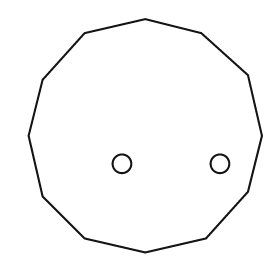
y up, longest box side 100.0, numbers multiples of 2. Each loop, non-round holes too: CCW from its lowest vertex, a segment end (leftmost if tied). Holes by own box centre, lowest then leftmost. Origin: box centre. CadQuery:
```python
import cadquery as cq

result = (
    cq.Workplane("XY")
    .moveTo(0.0, -50.0)
    .lineTo(26.0, -44.0)
    .lineTo(44.0, -24.0)
    .lineTo(50.0, 0.0)
    .lineTo(44.0, 26.0)
    .lineTo(24.0, 44.0)
    .lineTo(0.0, 50.0)
    .lineTo(-26.0, 44.0)
    .lineTo(-44.0, 24.0)
    .lineTo(-50.0, 0.0)
    .lineTo(-44.0, -26.0)
    .lineTo(-26.0, -44.0)
    .close()
    .moveTo(-10.0, -12.0)
    .circle(4.0)
    .moveTo(32.0, -12.0)
    .circle(4.0)
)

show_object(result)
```